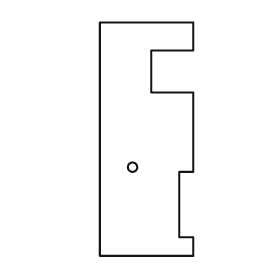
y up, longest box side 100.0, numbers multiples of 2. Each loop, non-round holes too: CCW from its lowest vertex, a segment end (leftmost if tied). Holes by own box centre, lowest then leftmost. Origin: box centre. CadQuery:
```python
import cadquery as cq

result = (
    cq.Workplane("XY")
    .moveTo(-20.0, -50.0)
    .lineTo(20.0, -50.0)
    .lineTo(20.0, -42.0)
    .lineTo(14.0, -42.0)
    .lineTo(14.0, -14.0)
    .lineTo(20.0, -14.0)
    .lineTo(20.0, 20.0)
    .lineTo(2.0, 20.0)
    .lineTo(2.0, 38.0)
    .lineTo(20.0, 38.0)
    .lineTo(20.0, 50.0)
    .lineTo(-20.0, 50.0)
    .close()
    .moveTo(-6.0, -12.0)
    .circle(2.0)
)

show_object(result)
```